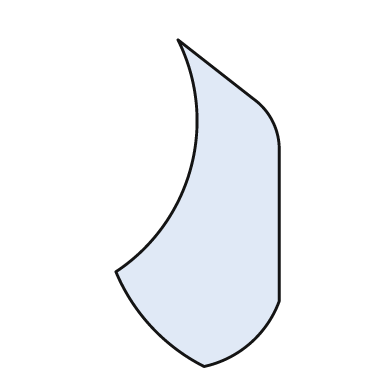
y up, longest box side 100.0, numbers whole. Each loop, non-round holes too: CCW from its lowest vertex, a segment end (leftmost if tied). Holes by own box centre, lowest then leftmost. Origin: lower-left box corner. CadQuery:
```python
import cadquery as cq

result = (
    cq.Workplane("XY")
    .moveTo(27.0, 0.0)
    .threePointArc((41.0, 7.0), (50.0, 20.0))
    .lineTo(50.0, 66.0)
    .threePointArc((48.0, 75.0), (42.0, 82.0))
    .lineTo(19.0, 100.0)
    .threePointArc((23.0, 61.0), (0.0, 29.0))
    .threePointArc((11.0, 12.0), (27.0, 0.0))
    .close()
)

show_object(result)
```